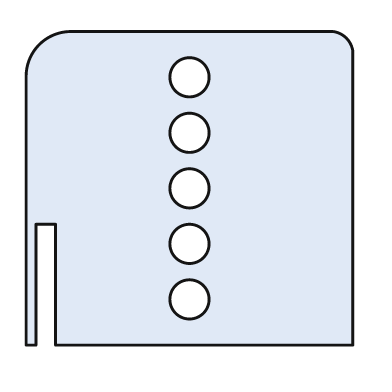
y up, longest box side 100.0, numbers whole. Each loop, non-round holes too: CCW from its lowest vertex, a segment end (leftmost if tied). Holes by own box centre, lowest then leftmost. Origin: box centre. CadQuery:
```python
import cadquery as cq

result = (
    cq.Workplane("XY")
    .moveTo(-50.0, -48.0)
    .lineTo(-47.0, -48.0)
    .lineTo(-47.0, -11.0)
    .lineTo(-41.0, -11.0)
    .lineTo(-41.0, -48.0)
    .lineTo(50.0, -48.0)
    .lineTo(50.0, 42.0)
    .threePointArc((48.0, 46.0), (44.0, 48.0))
    .lineTo(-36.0, 48.0)
    .threePointArc((-46.0, 44.0), (-50.0, 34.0))
    .close()
    .moveTo(0.0, -34.0)
    .circle(6.0)
    .moveTo(0.0, -17.0)
    .circle(6.0)
    .moveTo(0.0, 0.0)
    .circle(6.0)
    .moveTo(0.0, 17.0)
    .circle(6.0)
    .moveTo(0.0, 34.0)
    .circle(6.0)
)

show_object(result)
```